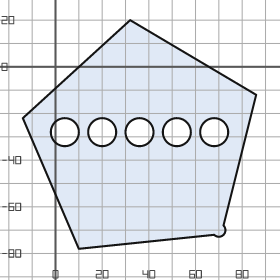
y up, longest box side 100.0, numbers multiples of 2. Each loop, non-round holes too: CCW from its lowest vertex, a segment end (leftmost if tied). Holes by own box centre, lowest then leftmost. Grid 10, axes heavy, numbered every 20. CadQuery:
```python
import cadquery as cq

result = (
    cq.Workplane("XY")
    .moveTo(10.0, -78.0)
    .lineTo(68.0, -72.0)
    .threePointArc((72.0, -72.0), (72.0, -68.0))
    .lineTo(86.0, -12.0)
    .lineTo(32.0, 20.0)
    .lineTo(-14.0, -22.0)
    .close()
    .moveTo(4.0, -28.0)
    .circle(6.0)
    .moveTo(20.0, -28.0)
    .circle(6.0)
    .moveTo(36.0, -28.0)
    .circle(6.0)
    .moveTo(52.0, -28.0)
    .circle(6.0)
    .moveTo(68.0, -28.0)
    .circle(6.0)
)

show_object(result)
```